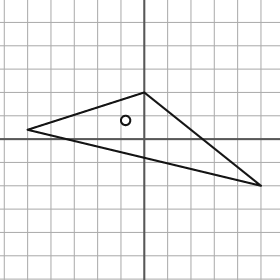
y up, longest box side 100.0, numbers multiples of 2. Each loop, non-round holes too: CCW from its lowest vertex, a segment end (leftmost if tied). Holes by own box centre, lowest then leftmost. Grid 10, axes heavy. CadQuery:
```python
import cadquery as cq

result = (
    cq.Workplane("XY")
    .moveTo(50.0, -20.0)
    .lineTo(0.0, 20.0)
    .lineTo(-50.0, 4.0)
    .close()
    .moveTo(-8.0, 8.0)
    .circle(2.0)
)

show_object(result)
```